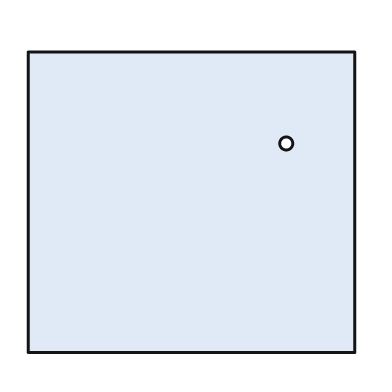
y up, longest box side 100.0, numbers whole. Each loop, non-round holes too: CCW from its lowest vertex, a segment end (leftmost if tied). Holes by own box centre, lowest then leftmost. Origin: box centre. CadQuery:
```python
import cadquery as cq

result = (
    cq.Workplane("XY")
    .moveTo(-50.0, -46.0)
    .lineTo(50.0, -46.0)
    .lineTo(50.0, 46.0)
    .lineTo(-50.0, 46.0)
    .close()
    .moveTo(29.0, 18.0)
    .circle(2.0)
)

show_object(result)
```